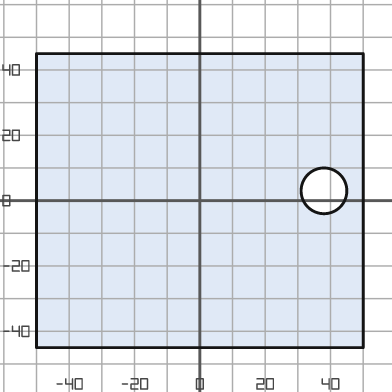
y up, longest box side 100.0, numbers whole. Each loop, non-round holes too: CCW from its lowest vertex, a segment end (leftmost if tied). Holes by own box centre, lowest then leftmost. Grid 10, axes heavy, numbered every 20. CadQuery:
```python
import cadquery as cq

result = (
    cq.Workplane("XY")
    .moveTo(-50.0, -45.0)
    .lineTo(50.0, -45.0)
    .lineTo(50.0, 45.0)
    .lineTo(-50.0, 45.0)
    .close()
    .moveTo(38.0, 3.0)
    .circle(7.0)
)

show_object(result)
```